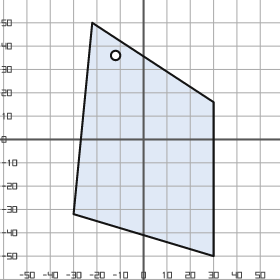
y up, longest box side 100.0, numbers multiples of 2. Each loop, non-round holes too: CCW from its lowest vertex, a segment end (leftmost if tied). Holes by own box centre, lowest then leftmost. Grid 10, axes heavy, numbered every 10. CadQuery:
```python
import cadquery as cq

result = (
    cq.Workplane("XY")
    .moveTo(30.0, -50.0)
    .lineTo(30.0, 16.0)
    .lineTo(-22.0, 50.0)
    .lineTo(-30.0, -32.0)
    .close()
    .moveTo(-12.0, 36.0)
    .circle(2.0)
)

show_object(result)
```